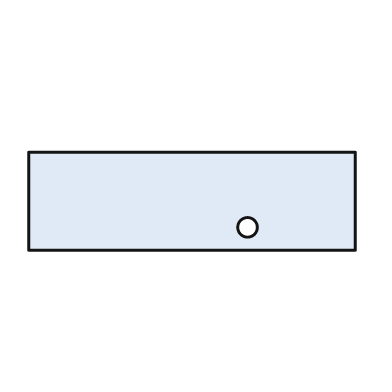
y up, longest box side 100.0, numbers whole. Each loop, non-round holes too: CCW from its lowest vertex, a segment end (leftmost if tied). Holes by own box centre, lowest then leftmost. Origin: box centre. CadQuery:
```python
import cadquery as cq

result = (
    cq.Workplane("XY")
    .moveTo(-50.0, -15.0)
    .lineTo(50.0, -15.0)
    .lineTo(50.0, 15.0)
    .lineTo(-50.0, 15.0)
    .close()
    .moveTo(17.0, -8.0)
    .circle(3.0)
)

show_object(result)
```